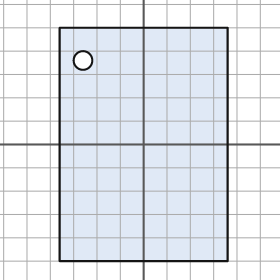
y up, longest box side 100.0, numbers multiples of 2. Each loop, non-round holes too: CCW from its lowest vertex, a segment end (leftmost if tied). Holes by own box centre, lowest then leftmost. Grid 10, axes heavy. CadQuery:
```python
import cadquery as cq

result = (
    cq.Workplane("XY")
    .moveTo(-36.0, -50.0)
    .lineTo(36.0, -50.0)
    .lineTo(36.0, 50.0)
    .lineTo(-36.0, 50.0)
    .close()
    .moveTo(-26.0, 36.0)
    .circle(4.0)
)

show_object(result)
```